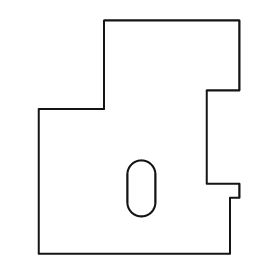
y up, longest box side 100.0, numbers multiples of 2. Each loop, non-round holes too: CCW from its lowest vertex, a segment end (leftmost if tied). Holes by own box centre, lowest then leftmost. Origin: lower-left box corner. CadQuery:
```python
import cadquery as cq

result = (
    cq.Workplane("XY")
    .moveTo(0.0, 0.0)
    .lineTo(82.0, 0.0)
    .lineTo(82.0, 24.0)
    .lineTo(86.0, 24.0)
    .lineTo(86.0, 30.0)
    .lineTo(72.0, 30.0)
    .lineTo(72.0, 70.0)
    .lineTo(86.0, 70.0)
    .lineTo(86.0, 100.0)
    .lineTo(28.0, 100.0)
    .lineTo(28.0, 62.0)
    .lineTo(0.0, 62.0)
    .close()
    .moveTo(38.0, 22.0)
    .threePointArc((44.0, 16.0), (50.0, 22.0))
    .lineTo(50.0, 34.0)
    .threePointArc((44.0, 40.0), (38.0, 34.0))
    .close()
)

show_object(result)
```